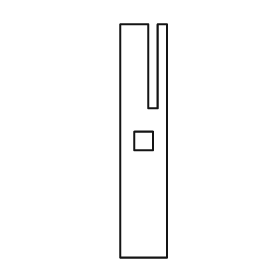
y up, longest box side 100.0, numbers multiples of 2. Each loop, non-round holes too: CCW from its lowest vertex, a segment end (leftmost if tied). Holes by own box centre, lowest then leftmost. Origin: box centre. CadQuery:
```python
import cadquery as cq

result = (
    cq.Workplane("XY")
    .moveTo(-10.0, -50.0)
    .lineTo(10.0, -50.0)
    .lineTo(10.0, 50.0)
    .lineTo(6.0, 50.0)
    .lineTo(6.0, 14.0)
    .lineTo(2.0, 14.0)
    .lineTo(2.0, 50.0)
    .lineTo(-10.0, 50.0)
    .close()
    .moveTo(-4.0, -4.0)
    .lineTo(4.0, -4.0)
    .lineTo(4.0, 4.0)
    .lineTo(-4.0, 4.0)
    .close()
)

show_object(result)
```